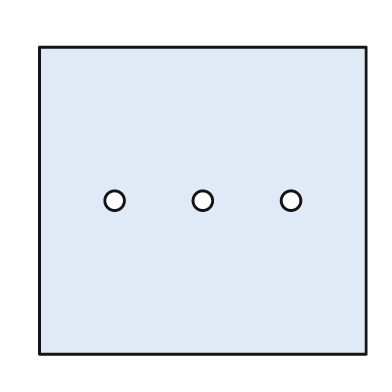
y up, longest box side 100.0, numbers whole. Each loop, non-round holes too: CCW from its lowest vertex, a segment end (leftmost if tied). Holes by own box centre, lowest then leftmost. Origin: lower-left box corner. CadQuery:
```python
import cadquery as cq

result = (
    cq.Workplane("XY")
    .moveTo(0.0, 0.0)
    .lineTo(100.0, 0.0)
    .lineTo(100.0, 94.0)
    .lineTo(0.0, 94.0)
    .close()
    .moveTo(23.0, 47.0)
    .circle(3.0)
    .moveTo(50.0, 47.0)
    .circle(3.0)
    .moveTo(77.0, 47.0)
    .circle(3.0)
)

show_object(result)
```